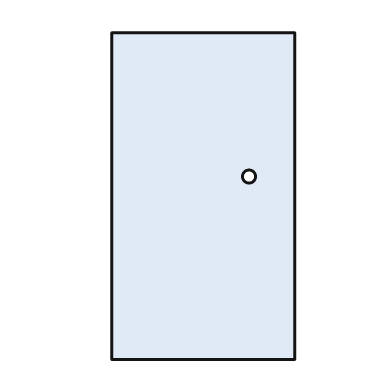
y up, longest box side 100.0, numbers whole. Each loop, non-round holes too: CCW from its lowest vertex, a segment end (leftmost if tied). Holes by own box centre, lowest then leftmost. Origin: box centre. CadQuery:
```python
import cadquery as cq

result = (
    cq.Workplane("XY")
    .moveTo(-28.0, -50.0)
    .lineTo(28.0, -50.0)
    .lineTo(28.0, 50.0)
    .lineTo(-28.0, 50.0)
    .close()
    .moveTo(14.0, 6.0)
    .circle(2.0)
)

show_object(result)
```